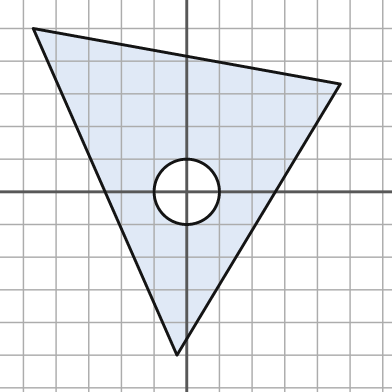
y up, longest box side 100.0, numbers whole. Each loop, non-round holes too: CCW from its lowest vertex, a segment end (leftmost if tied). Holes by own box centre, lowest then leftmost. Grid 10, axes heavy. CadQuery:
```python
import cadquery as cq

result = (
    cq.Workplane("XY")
    .moveTo(-3.0, -50.0)
    .lineTo(47.0, 33.0)
    .lineTo(-47.0, 50.0)
    .close()
    .moveTo(0.0, 0.0)
    .circle(10.0)
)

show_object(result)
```